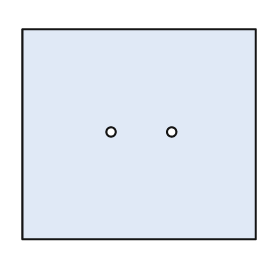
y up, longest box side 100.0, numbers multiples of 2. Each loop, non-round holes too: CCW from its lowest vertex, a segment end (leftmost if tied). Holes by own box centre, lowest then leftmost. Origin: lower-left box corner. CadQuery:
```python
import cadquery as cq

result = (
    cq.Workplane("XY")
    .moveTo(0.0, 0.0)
    .lineTo(100.0, 0.0)
    .lineTo(100.0, 90.0)
    .lineTo(0.0, 90.0)
    .close()
    .moveTo(38.0, 46.0)
    .circle(2.0)
    .moveTo(64.0, 46.0)
    .circle(2.0)
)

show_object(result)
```